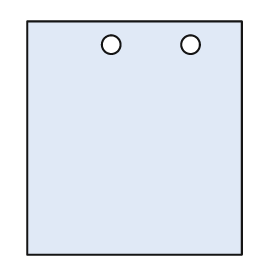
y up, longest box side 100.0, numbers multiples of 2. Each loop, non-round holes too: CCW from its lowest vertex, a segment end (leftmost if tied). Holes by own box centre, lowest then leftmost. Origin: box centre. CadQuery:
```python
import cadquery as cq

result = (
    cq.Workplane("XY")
    .moveTo(-46.0, -50.0)
    .lineTo(46.0, -50.0)
    .lineTo(46.0, 50.0)
    .lineTo(-46.0, 50.0)
    .close()
    .moveTo(-10.0, 40.0)
    .circle(4.0)
    .moveTo(24.0, 40.0)
    .circle(4.0)
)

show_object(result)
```